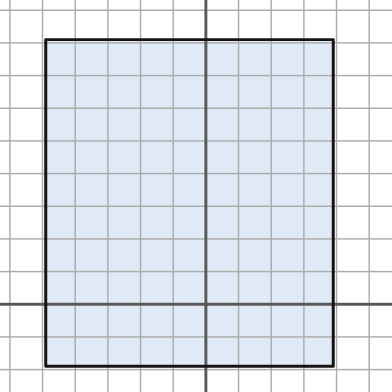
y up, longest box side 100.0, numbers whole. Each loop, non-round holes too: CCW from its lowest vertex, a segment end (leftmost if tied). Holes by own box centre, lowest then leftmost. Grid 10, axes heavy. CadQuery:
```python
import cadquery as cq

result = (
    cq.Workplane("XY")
    .moveTo(-49.0, -19.0)
    .lineTo(39.0, -19.0)
    .lineTo(39.0, 81.0)
    .lineTo(-49.0, 81.0)
    .close()
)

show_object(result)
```